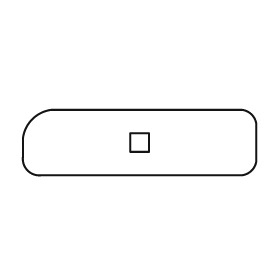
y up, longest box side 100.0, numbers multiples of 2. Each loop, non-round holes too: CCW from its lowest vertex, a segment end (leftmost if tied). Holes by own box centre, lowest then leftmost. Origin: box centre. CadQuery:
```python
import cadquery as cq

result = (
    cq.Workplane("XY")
    .moveTo(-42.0, -14.0)
    .lineTo(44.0, -14.0)
    .threePointArc((48.0, -12.0), (50.0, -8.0))
    .lineTo(50.0, 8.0)
    .threePointArc((48.0, 12.0), (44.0, 14.0))
    .lineTo(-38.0, 14.0)
    .threePointArc((-46.0, 10.0), (-50.0, 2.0))
    .lineTo(-50.0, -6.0)
    .threePointArc((-48.0, -12.0), (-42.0, -14.0))
    .close()
    .moveTo(-4.0, -4.0)
    .lineTo(4.0, -4.0)
    .lineTo(4.0, 4.0)
    .lineTo(-4.0, 4.0)
    .close()
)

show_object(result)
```